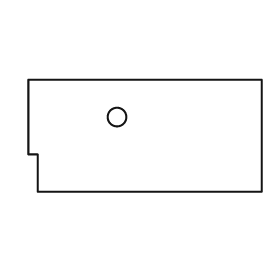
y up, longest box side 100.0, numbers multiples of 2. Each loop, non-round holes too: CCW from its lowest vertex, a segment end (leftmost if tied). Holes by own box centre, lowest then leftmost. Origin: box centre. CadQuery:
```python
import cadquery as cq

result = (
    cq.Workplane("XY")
    .moveTo(-46.0, -24.0)
    .lineTo(50.0, -24.0)
    .lineTo(50.0, 24.0)
    .lineTo(-50.0, 24.0)
    .lineTo(-50.0, -8.0)
    .lineTo(-46.0, -8.0)
    .close()
    .moveTo(-12.0, 8.0)
    .circle(4.0)
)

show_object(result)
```